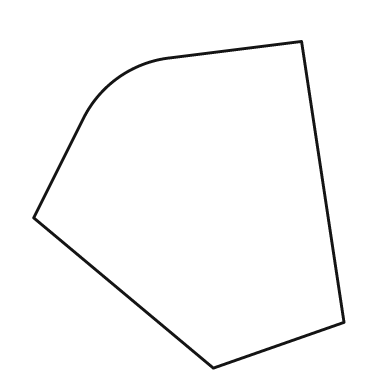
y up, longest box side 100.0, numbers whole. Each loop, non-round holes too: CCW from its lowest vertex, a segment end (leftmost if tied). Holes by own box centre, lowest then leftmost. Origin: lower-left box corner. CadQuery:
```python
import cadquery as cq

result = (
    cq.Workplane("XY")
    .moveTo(55.0, 0.0)
    .lineTo(95.0, 14.0)
    .lineTo(82.0, 100.0)
    .lineTo(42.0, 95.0)
    .threePointArc((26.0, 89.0), (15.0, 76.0))
    .lineTo(0.0, 46.0)
    .close()
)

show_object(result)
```